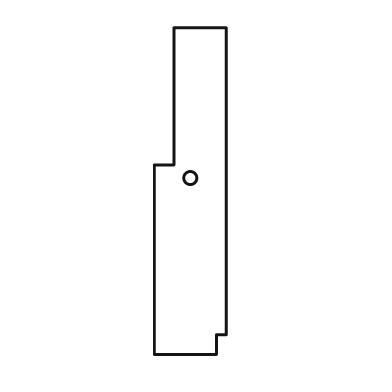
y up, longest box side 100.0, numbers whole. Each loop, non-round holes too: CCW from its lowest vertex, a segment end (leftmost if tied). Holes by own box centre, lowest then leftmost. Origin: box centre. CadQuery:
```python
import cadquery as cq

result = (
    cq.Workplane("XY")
    .moveTo(-11.0, -50.0)
    .lineTo(8.0, -50.0)
    .lineTo(8.0, -44.0)
    .lineTo(11.0, -44.0)
    .lineTo(11.0, 50.0)
    .lineTo(-5.0, 50.0)
    .lineTo(-5.0, 8.0)
    .lineTo(-11.0, 8.0)
    .close()
    .moveTo(0.0, 4.0)
    .circle(2.0)
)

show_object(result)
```